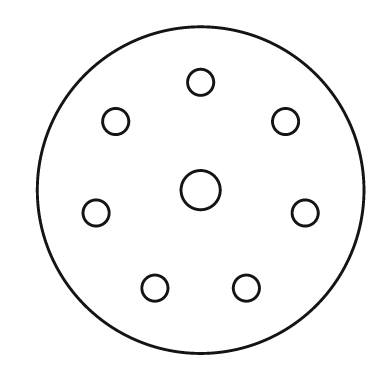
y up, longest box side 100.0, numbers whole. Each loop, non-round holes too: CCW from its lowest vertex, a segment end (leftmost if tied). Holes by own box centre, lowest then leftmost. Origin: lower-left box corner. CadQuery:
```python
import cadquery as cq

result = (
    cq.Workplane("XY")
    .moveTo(50.0, 50.0)
    .circle(50.0)
    .moveTo(36.0, 20.0)
    .circle(4.0)
    .moveTo(64.0, 20.0)
    .circle(4.0)
    .moveTo(18.0, 43.0)
    .circle(4.0)
    .moveTo(82.0, 43.0)
    .circle(4.0)
    .moveTo(50.0, 50.0)
    .circle(6.0)
    .moveTo(24.0, 71.0)
    .circle(4.0)
    .moveTo(76.0, 71.0)
    .circle(4.0)
    .moveTo(50.0, 83.0)
    .circle(4.0)
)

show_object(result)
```